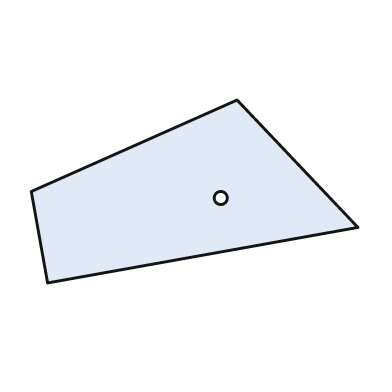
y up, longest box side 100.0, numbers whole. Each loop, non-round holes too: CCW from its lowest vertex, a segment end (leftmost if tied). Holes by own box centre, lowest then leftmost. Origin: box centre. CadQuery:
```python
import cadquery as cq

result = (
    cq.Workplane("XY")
    .moveTo(-45.0, -28.0)
    .lineTo(50.0, -11.0)
    .lineTo(13.0, 28.0)
    .lineTo(-50.0, 0.0)
    .close()
    .moveTo(8.0, -2.0)
    .circle(2.0)
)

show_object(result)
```